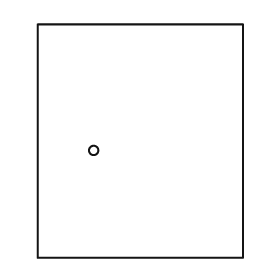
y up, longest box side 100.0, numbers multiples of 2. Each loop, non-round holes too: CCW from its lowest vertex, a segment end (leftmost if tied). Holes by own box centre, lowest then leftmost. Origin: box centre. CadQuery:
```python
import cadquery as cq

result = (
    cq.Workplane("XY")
    .moveTo(-44.0, -50.0)
    .lineTo(44.0, -50.0)
    .lineTo(44.0, 50.0)
    .lineTo(-44.0, 50.0)
    .close()
    .moveTo(-20.0, -4.0)
    .circle(2.0)
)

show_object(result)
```